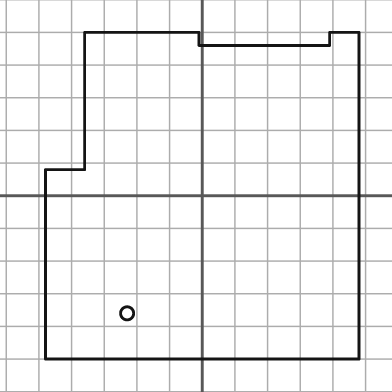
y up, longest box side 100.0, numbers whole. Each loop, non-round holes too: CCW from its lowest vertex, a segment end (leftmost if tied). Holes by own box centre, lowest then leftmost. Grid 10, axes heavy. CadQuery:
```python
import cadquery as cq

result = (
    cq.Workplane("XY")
    .moveTo(-48.0, -50.0)
    .lineTo(48.0, -50.0)
    .lineTo(48.0, 50.0)
    .lineTo(39.0, 50.0)
    .lineTo(39.0, 46.0)
    .lineTo(-1.0, 46.0)
    .lineTo(-1.0, 50.0)
    .lineTo(-36.0, 50.0)
    .lineTo(-36.0, 8.0)
    .lineTo(-48.0, 8.0)
    .close()
    .moveTo(-23.0, -36.0)
    .circle(2.0)
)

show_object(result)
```